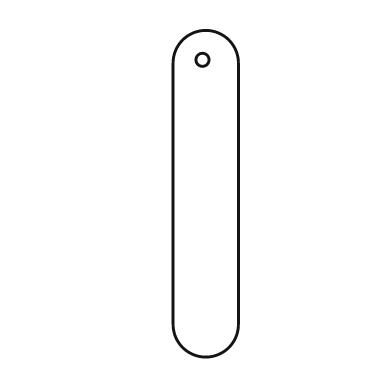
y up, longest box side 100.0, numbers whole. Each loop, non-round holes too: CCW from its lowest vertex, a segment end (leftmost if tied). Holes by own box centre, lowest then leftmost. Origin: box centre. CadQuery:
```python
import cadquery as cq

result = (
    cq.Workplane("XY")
    .moveTo(-10.0, -40.0)
    .threePointArc((0.0, -50.0), (10.0, -40.0))
    .lineTo(10.0, 40.0)
    .threePointArc((0.0, 50.0), (-10.0, 40.0))
    .close()
    .moveTo(-1.0, 41.0)
    .circle(2.0)
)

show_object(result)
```